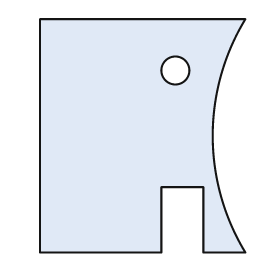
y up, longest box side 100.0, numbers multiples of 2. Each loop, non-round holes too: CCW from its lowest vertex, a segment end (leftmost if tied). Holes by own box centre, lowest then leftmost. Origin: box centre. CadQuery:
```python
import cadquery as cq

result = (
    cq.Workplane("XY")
    .moveTo(-44.0, -50.0)
    .lineTo(8.0, -50.0)
    .lineTo(8.0, -22.0)
    .lineTo(26.0, -22.0)
    .lineTo(26.0, -50.0)
    .lineTo(44.0, -50.0)
    .threePointArc((30.0, 0.0), (44.0, 50.0))
    .lineTo(-44.0, 50.0)
    .close()
    .moveTo(14.0, 28.0)
    .circle(6.0)
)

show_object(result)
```